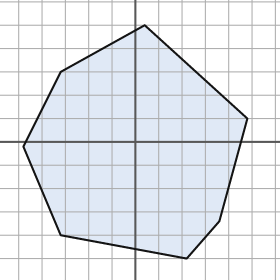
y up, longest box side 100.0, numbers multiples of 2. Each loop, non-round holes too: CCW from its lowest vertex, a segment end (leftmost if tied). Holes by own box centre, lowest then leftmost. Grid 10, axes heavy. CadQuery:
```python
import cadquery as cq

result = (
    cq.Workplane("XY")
    .moveTo(22.0, -50.0)
    .lineTo(36.0, -34.0)
    .lineTo(48.0, 10.0)
    .lineTo(4.0, 50.0)
    .lineTo(-32.0, 30.0)
    .lineTo(-48.0, -2.0)
    .lineTo(-32.0, -40.0)
    .close()
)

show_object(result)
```